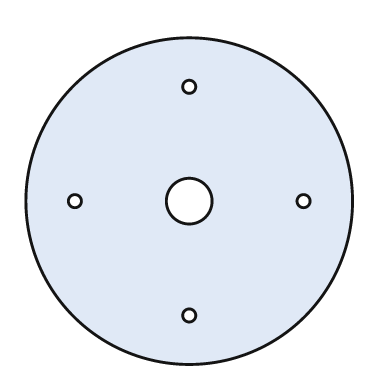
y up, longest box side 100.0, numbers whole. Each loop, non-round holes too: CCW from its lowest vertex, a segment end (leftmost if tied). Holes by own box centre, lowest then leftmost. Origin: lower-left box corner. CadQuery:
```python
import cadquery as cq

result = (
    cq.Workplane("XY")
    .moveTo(50.0, 50.0)
    .circle(50.0)
    .moveTo(50.0, 15.0)
    .circle(2.0)
    .moveTo(15.0, 50.0)
    .circle(2.0)
    .moveTo(50.0, 50.0)
    .circle(7.0)
    .moveTo(85.0, 50.0)
    .circle(2.0)
    .moveTo(50.0, 85.0)
    .circle(2.0)
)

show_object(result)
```